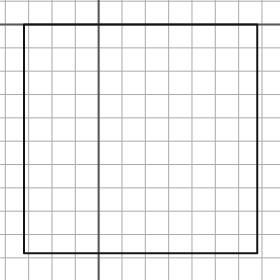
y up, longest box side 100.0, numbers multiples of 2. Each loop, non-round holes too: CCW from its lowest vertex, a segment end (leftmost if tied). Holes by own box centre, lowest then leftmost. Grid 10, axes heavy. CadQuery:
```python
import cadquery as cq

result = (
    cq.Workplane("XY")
    .moveTo(-32.0, -98.0)
    .lineTo(68.0, -98.0)
    .lineTo(68.0, 0.0)
    .lineTo(-32.0, 0.0)
    .close()
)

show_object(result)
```